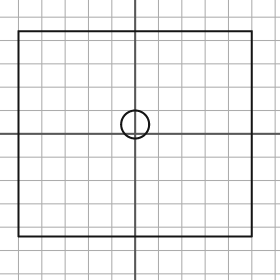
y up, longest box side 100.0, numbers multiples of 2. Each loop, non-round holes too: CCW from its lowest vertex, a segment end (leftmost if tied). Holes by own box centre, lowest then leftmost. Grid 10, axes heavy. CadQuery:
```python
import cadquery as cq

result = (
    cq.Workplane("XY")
    .moveTo(-50.0, -44.0)
    .lineTo(50.0, -44.0)
    .lineTo(50.0, 44.0)
    .lineTo(-50.0, 44.0)
    .close()
    .moveTo(0.0, 4.0)
    .circle(6.0)
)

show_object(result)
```